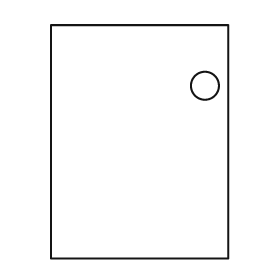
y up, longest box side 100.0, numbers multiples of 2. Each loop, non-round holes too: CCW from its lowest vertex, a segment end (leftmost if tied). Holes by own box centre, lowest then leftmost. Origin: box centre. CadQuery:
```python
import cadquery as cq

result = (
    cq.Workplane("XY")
    .moveTo(-38.0, -50.0)
    .lineTo(38.0, -50.0)
    .lineTo(38.0, 50.0)
    .lineTo(-38.0, 50.0)
    .close()
    .moveTo(28.0, 24.0)
    .circle(6.0)
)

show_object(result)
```